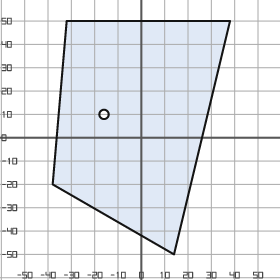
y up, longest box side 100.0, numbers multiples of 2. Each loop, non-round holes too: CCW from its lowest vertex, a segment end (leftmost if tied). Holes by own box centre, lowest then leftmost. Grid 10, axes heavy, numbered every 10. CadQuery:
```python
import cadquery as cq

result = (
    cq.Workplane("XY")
    .moveTo(14.0, -50.0)
    .lineTo(38.0, 50.0)
    .lineTo(-32.0, 50.0)
    .lineTo(-38.0, -20.0)
    .close()
    .moveTo(-16.0, 10.0)
    .circle(2.0)
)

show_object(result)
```